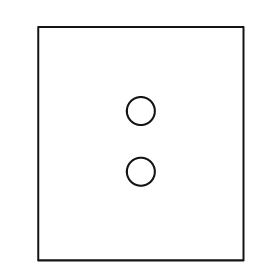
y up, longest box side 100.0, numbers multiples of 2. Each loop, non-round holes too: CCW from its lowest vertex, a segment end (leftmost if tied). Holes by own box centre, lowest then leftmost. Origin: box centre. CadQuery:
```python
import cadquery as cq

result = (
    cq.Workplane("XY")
    .moveTo(-44.0, -50.0)
    .lineTo(44.0, -50.0)
    .lineTo(44.0, 50.0)
    .lineTo(-44.0, 50.0)
    .close()
    .moveTo(0.0, -12.0)
    .circle(6.0)
    .moveTo(0.0, 14.0)
    .circle(6.0)
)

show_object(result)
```